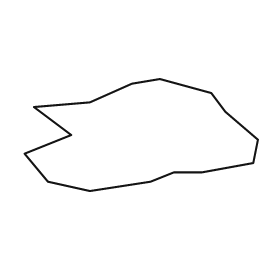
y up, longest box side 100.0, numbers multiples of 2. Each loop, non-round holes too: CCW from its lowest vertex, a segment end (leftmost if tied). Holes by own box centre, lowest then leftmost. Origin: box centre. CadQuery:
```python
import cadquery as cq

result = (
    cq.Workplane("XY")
    .moveTo(-22.0, -24.0)
    .lineTo(4.0, -20.0)
    .lineTo(14.0, -16.0)
    .lineTo(26.0, -16.0)
    .lineTo(48.0, -12.0)
    .lineTo(50.0, -2.0)
    .lineTo(36.0, 10.0)
    .lineTo(30.0, 18.0)
    .lineTo(8.0, 24.0)
    .lineTo(-4.0, 22.0)
    .lineTo(-22.0, 14.0)
    .lineTo(-46.0, 12.0)
    .lineTo(-30.0, 0.0)
    .lineTo(-50.0, -8.0)
    .lineTo(-40.0, -20.0)
    .close()
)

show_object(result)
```